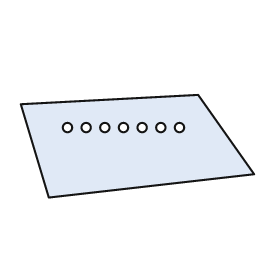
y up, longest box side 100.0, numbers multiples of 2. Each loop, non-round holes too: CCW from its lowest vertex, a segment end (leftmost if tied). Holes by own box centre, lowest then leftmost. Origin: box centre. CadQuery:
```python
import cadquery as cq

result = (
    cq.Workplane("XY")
    .moveTo(-38.0, -22.0)
    .lineTo(50.0, -12.0)
    .lineTo(26.0, 22.0)
    .lineTo(-50.0, 18.0)
    .close()
    .moveTo(-30.0, 8.0)
    .circle(2.0)
    .moveTo(-22.0, 8.0)
    .circle(2.0)
    .moveTo(-14.0, 8.0)
    .circle(2.0)
    .moveTo(-6.0, 8.0)
    .circle(2.0)
    .moveTo(2.0, 8.0)
    .circle(2.0)
    .moveTo(10.0, 8.0)
    .circle(2.0)
    .moveTo(18.0, 8.0)
    .circle(2.0)
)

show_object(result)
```